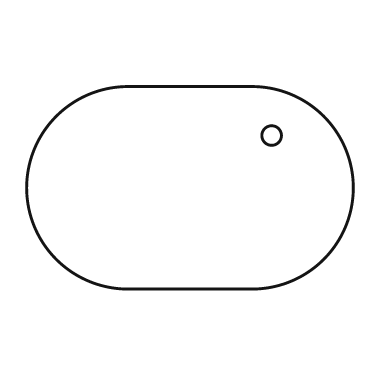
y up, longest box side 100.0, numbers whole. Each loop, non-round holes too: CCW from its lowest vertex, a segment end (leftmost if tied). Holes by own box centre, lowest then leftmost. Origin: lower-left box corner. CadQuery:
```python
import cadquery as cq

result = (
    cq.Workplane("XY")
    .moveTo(31.0, 0.0)
    .lineTo(69.0, 0.0)
    .threePointArc((100.0, 31.0), (69.0, 62.0))
    .lineTo(31.0, 62.0)
    .threePointArc((0.0, 31.0), (31.0, 0.0))
    .close()
    .moveTo(75.0, 47.0)
    .circle(3.0)
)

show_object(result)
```